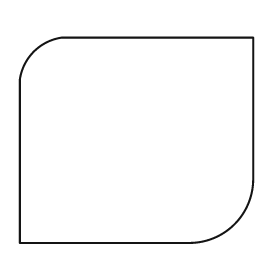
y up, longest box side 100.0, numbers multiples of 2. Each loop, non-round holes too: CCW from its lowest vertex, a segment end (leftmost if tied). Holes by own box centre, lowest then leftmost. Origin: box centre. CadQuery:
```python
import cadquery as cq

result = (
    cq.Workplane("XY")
    .moveTo(-50.0, -44.0)
    .lineTo(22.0, -44.0)
    .threePointArc((42.0, -36.0), (50.0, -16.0))
    .lineTo(50.0, 44.0)
    .lineTo(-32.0, 44.0)
    .threePointArc((-44.0, 38.0), (-50.0, 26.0))
    .close()
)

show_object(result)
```